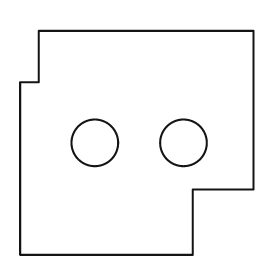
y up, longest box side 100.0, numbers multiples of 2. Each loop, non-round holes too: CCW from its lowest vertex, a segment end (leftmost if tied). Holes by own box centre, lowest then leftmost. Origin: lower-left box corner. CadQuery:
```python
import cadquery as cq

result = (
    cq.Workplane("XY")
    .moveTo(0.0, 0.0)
    .lineTo(74.0, 0.0)
    .lineTo(74.0, 28.0)
    .lineTo(100.0, 28.0)
    .lineTo(100.0, 96.0)
    .lineTo(8.0, 96.0)
    .lineTo(8.0, 74.0)
    .lineTo(0.0, 74.0)
    .close()
    .moveTo(32.0, 48.0)
    .circle(10.0)
    .moveTo(70.0, 48.0)
    .circle(10.0)
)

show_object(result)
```